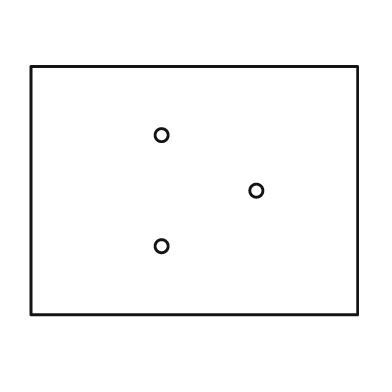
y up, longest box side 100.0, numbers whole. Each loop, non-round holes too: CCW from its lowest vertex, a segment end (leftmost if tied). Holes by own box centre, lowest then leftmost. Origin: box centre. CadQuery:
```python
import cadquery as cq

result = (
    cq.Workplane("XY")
    .moveTo(-50.0, -38.0)
    .lineTo(50.0, -38.0)
    .lineTo(50.0, 38.0)
    .lineTo(-50.0, 38.0)
    .close()
    .moveTo(-10.0, -17.0)
    .circle(2.0)
    .moveTo(19.0, 0.0)
    .circle(2.0)
    .moveTo(-10.0, 17.0)
    .circle(2.0)
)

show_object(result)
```